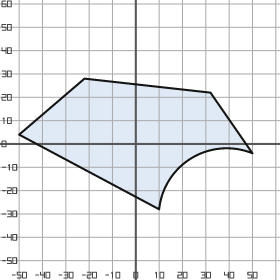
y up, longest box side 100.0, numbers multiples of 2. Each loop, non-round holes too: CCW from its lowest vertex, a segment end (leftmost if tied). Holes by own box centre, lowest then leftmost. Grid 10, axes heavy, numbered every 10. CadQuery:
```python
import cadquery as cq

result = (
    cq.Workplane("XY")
    .moveTo(10.0, -28.0)
    .threePointArc((24.0, -6.0), (50.0, -4.0))
    .lineTo(32.0, 22.0)
    .lineTo(-22.0, 28.0)
    .lineTo(-50.0, 4.0)
    .close()
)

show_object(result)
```